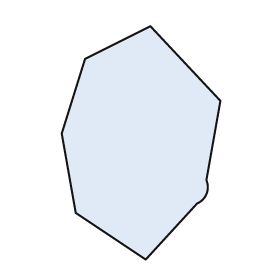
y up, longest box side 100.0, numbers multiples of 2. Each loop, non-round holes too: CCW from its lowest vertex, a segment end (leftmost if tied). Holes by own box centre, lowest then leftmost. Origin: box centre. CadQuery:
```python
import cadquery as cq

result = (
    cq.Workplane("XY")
    .moveTo(2.0, -50.0)
    .lineTo(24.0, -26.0)
    .threePointArc((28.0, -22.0), (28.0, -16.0))
    .lineTo(34.0, 18.0)
    .lineTo(4.0, 50.0)
    .lineTo(-24.0, 36.0)
    .lineTo(-34.0, 4.0)
    .lineTo(-28.0, -30.0)
    .close()
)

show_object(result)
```